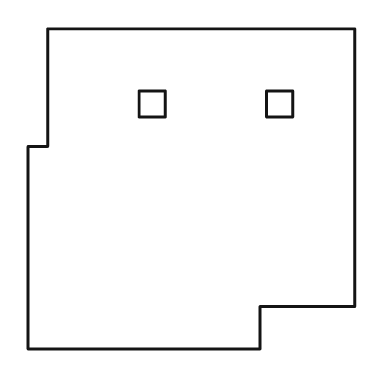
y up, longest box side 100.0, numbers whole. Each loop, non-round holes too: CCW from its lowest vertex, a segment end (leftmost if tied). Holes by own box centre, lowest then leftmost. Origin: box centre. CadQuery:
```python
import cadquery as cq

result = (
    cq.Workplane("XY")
    .moveTo(-50.0, -49.0)
    .lineTo(21.0, -49.0)
    .lineTo(21.0, -36.0)
    .lineTo(50.0, -36.0)
    .lineTo(50.0, 49.0)
    .lineTo(-44.0, 49.0)
    .lineTo(-44.0, 13.0)
    .lineTo(-50.0, 13.0)
    .close()
    .moveTo(-16.0, 22.0)
    .lineTo(-8.0, 22.0)
    .lineTo(-8.0, 30.0)
    .lineTo(-16.0, 30.0)
    .close()
    .moveTo(23.0, 22.0)
    .lineTo(31.0, 22.0)
    .lineTo(31.0, 30.0)
    .lineTo(23.0, 30.0)
    .close()
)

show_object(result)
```